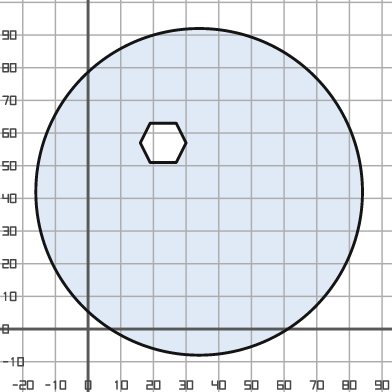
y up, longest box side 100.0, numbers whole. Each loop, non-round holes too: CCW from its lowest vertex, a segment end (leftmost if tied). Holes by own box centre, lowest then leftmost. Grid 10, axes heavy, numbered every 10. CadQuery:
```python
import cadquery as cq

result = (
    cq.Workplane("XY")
    .moveTo(34.0, 42.0)
    .circle(50.0)
    .moveTo(19.0, 51.0)
    .lineTo(27.0, 51.0)
    .lineTo(30.0, 57.0)
    .lineTo(27.0, 63.0)
    .lineTo(19.0, 63.0)
    .lineTo(16.0, 57.0)
    .close()
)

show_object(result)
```